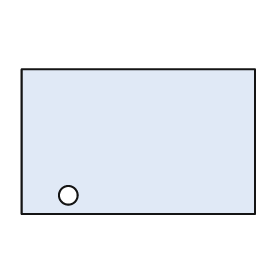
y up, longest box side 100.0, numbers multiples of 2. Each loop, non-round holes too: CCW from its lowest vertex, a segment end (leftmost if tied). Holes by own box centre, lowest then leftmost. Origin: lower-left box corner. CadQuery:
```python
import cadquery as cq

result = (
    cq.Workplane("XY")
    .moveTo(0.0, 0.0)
    .lineTo(100.0, 0.0)
    .lineTo(100.0, 62.0)
    .lineTo(0.0, 62.0)
    .close()
    .moveTo(20.0, 8.0)
    .circle(4.0)
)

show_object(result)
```